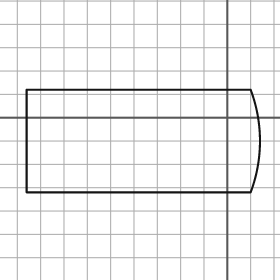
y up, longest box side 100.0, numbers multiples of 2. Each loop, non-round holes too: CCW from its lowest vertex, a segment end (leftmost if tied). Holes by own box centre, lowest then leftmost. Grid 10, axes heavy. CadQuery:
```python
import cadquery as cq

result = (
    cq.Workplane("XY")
    .moveTo(-86.0, -32.0)
    .lineTo(10.0, -32.0)
    .threePointArc((14.0, -10.0), (10.0, 12.0))
    .lineTo(-86.0, 12.0)
    .close()
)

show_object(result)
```